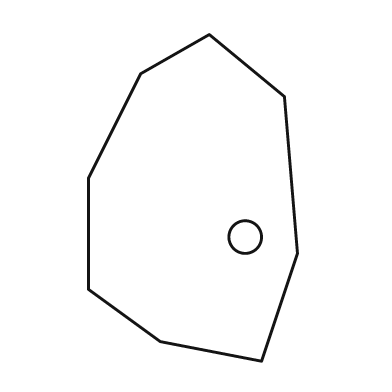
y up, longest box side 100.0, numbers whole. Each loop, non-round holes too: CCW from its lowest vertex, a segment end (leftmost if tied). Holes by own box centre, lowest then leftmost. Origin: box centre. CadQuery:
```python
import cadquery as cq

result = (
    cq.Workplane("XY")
    .moveTo(21.0, -50.0)
    .lineTo(32.0, -17.0)
    .lineTo(28.0, 31.0)
    .lineTo(5.0, 50.0)
    .lineTo(-16.0, 38.0)
    .lineTo(-32.0, 6.0)
    .lineTo(-32.0, -28.0)
    .lineTo(-10.0, -44.0)
    .close()
    .moveTo(16.0, -12.0)
    .circle(5.0)
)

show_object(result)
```